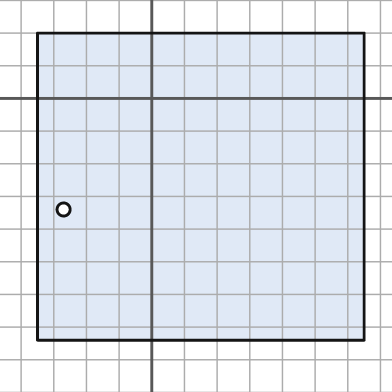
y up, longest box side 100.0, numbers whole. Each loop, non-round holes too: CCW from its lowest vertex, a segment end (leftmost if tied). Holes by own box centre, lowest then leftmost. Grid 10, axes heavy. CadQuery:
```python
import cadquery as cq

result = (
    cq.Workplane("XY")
    .moveTo(-35.0, -74.0)
    .lineTo(65.0, -74.0)
    .lineTo(65.0, 20.0)
    .lineTo(-35.0, 20.0)
    .close()
    .moveTo(-27.0, -34.0)
    .circle(2.0)
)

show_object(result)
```